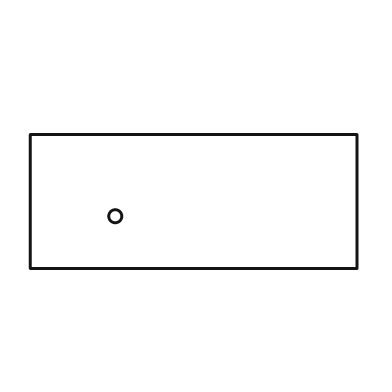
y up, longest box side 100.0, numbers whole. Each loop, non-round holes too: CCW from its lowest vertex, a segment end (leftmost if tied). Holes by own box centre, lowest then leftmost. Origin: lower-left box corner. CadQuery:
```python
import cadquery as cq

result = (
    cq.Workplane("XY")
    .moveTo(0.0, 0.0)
    .lineTo(100.0, 0.0)
    .lineTo(100.0, 41.0)
    .lineTo(0.0, 41.0)
    .close()
    .moveTo(26.0, 16.0)
    .circle(2.0)
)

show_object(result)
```